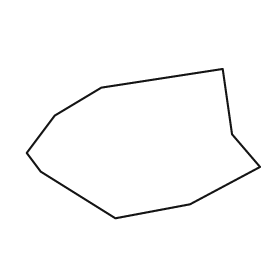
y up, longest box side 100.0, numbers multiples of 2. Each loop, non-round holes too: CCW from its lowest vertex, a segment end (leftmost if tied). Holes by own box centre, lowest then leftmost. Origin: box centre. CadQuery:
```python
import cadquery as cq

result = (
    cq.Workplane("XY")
    .moveTo(-12.0, -32.0)
    .lineTo(20.0, -26.0)
    .lineTo(50.0, -10.0)
    .lineTo(38.0, 4.0)
    .lineTo(34.0, 32.0)
    .lineTo(-18.0, 24.0)
    .lineTo(-38.0, 12.0)
    .lineTo(-50.0, -4.0)
    .lineTo(-44.0, -12.0)
    .close()
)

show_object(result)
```